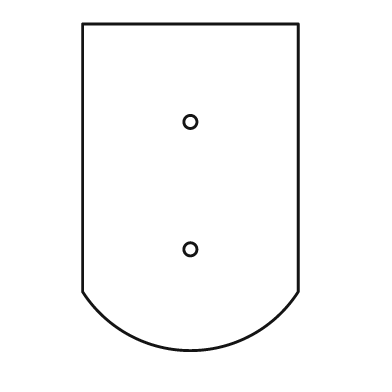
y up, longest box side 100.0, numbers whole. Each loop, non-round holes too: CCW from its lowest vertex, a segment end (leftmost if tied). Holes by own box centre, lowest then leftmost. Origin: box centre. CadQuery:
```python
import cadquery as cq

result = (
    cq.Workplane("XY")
    .moveTo(-33.0, -32.0)
    .threePointArc((0.0, -50.0), (33.0, -32.0))
    .lineTo(33.0, 50.0)
    .lineTo(-33.0, 50.0)
    .close()
    .moveTo(0.0, -19.0)
    .circle(2.0)
    .moveTo(0.0, 20.0)
    .circle(2.0)
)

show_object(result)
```